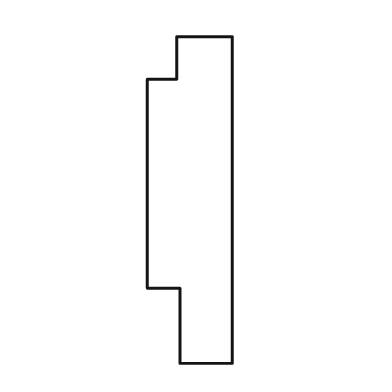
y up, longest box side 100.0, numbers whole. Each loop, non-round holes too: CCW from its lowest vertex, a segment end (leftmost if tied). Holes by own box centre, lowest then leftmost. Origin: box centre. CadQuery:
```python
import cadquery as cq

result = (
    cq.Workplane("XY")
    .moveTo(-3.0, -50.0)
    .lineTo(13.0, -50.0)
    .lineTo(13.0, 50.0)
    .lineTo(-4.0, 50.0)
    .lineTo(-4.0, 37.0)
    .lineTo(-13.0, 37.0)
    .lineTo(-13.0, -27.0)
    .lineTo(-3.0, -27.0)
    .close()
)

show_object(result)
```